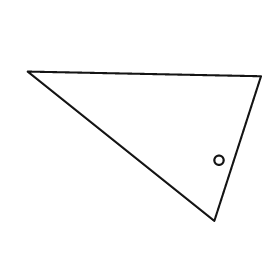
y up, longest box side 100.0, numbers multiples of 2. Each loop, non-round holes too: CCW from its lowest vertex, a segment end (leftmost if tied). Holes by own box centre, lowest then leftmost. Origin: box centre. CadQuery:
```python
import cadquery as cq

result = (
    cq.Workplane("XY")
    .moveTo(30.0, -32.0)
    .lineTo(50.0, 30.0)
    .lineTo(-50.0, 32.0)
    .close()
    .moveTo(32.0, -6.0)
    .circle(2.0)
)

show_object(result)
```